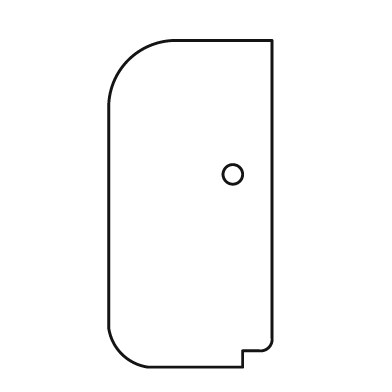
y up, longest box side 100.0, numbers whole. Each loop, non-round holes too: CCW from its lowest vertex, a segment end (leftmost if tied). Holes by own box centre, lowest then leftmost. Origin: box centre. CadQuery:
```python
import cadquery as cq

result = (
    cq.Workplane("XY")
    .moveTo(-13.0, -50.0)
    .lineTo(16.0, -50.0)
    .lineTo(16.0, -45.0)
    .lineTo(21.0, -45.0)
    .threePointArc((24.0, -44.0), (25.0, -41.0))
    .lineTo(25.0, 50.0)
    .lineTo(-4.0, 50.0)
    .threePointArc((-19.0, 44.0), (-25.0, 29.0))
    .lineTo(-25.0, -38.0)
    .threePointArc((-21.0, -46.0), (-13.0, -50.0))
    .close()
    .moveTo(13.0, 9.0)
    .circle(3.0)
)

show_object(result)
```